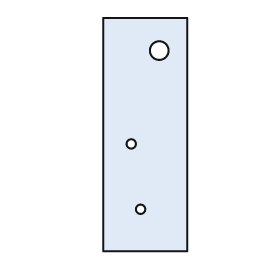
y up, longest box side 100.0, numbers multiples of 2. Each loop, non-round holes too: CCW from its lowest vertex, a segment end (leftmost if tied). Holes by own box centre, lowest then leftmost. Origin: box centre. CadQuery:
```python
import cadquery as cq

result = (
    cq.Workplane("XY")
    .moveTo(-18.0, -50.0)
    .lineTo(18.0, -50.0)
    .lineTo(18.0, 50.0)
    .lineTo(-18.0, 50.0)
    .close()
    .moveTo(-2.0, -32.0)
    .circle(2.0)
    .moveTo(-6.0, -4.0)
    .circle(2.0)
    .moveTo(6.0, 36.0)
    .circle(4.0)
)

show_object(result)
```